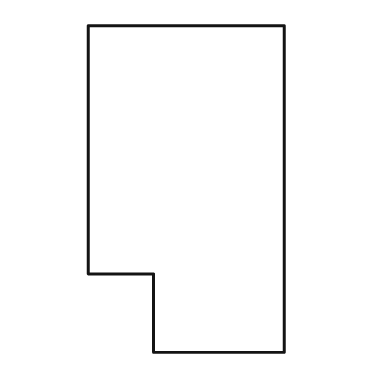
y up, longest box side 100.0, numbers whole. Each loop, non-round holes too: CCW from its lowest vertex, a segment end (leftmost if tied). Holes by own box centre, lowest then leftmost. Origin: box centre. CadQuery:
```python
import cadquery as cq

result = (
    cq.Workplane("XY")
    .moveTo(-10.0, -50.0)
    .lineTo(30.0, -50.0)
    .lineTo(30.0, 50.0)
    .lineTo(-30.0, 50.0)
    .lineTo(-30.0, -26.0)
    .lineTo(-10.0, -26.0)
    .close()
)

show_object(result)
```